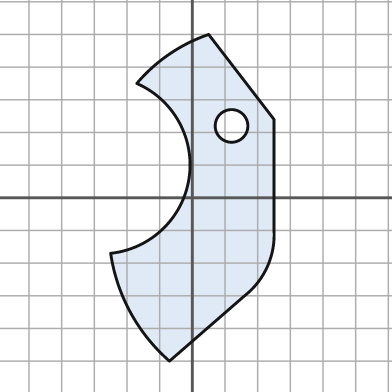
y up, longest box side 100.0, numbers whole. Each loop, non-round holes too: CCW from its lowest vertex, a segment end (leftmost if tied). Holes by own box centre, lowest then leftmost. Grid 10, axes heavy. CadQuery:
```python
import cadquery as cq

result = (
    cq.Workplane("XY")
    .moveTo(-7.0, -50.0)
    .lineTo(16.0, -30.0)
    .threePointArc((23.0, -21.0), (25.0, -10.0))
    .lineTo(25.0, 24.0)
    .lineTo(5.0, 50.0)
    .threePointArc((-7.0, 44.0), (-17.0, 35.0))
    .threePointArc((-1.0, 6.0), (-25.0, -17.0))
    .threePointArc((-19.0, -35.0), (-7.0, -50.0))
    .close()
    .moveTo(12.0, 22.0)
    .circle(5.0)
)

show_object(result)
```